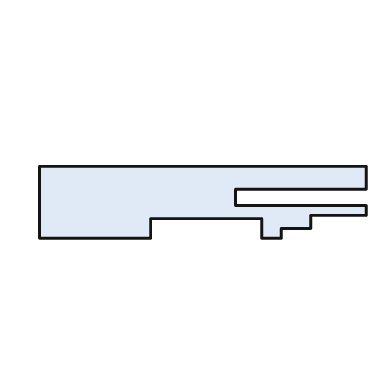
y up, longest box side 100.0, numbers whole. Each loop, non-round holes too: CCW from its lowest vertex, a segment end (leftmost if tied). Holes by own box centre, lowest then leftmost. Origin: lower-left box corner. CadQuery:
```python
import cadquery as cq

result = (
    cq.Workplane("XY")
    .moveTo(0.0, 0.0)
    .lineTo(34.0, 0.0)
    .lineTo(34.0, 6.0)
    .lineTo(68.0, 6.0)
    .lineTo(68.0, 0.0)
    .lineTo(74.0, 0.0)
    .lineTo(74.0, 3.0)
    .lineTo(83.0, 3.0)
    .lineTo(83.0, 7.0)
    .lineTo(100.0, 7.0)
    .lineTo(100.0, 10.0)
    .lineTo(60.0, 10.0)
    .lineTo(60.0, 15.0)
    .lineTo(100.0, 15.0)
    .lineTo(100.0, 22.0)
    .lineTo(0.0, 22.0)
    .close()
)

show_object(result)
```